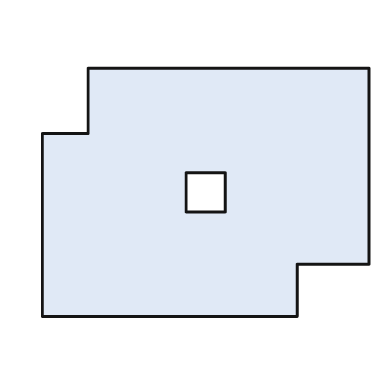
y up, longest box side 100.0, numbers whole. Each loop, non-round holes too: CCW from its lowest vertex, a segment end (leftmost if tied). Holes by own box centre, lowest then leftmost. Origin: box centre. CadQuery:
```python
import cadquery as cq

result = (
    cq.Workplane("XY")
    .moveTo(-50.0, -38.0)
    .lineTo(28.0, -38.0)
    .lineTo(28.0, -22.0)
    .lineTo(50.0, -22.0)
    .lineTo(50.0, 38.0)
    .lineTo(-36.0, 38.0)
    .lineTo(-36.0, 18.0)
    .lineTo(-50.0, 18.0)
    .close()
    .moveTo(-6.0, -6.0)
    .lineTo(6.0, -6.0)
    .lineTo(6.0, 6.0)
    .lineTo(-6.0, 6.0)
    .close()
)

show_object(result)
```